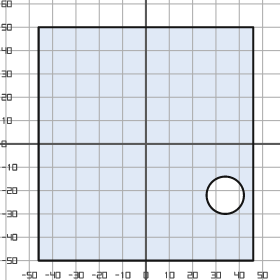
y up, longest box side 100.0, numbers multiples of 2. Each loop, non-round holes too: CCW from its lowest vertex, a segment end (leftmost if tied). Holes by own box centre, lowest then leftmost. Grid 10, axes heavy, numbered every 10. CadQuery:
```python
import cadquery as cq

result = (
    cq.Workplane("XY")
    .moveTo(-46.0, -50.0)
    .lineTo(46.0, -50.0)
    .lineTo(46.0, 50.0)
    .lineTo(-46.0, 50.0)
    .close()
    .moveTo(34.0, -22.0)
    .circle(8.0)
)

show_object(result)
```